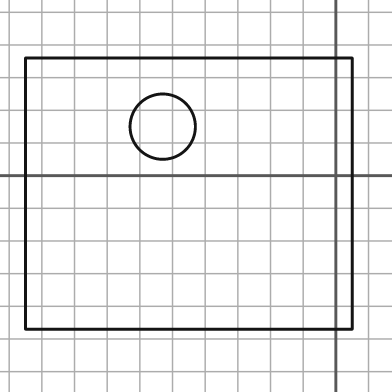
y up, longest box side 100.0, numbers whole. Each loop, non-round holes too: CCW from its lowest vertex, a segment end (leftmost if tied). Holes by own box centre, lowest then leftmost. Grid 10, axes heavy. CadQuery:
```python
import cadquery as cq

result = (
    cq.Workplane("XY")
    .moveTo(-95.0, -47.0)
    .lineTo(5.0, -47.0)
    .lineTo(5.0, 36.0)
    .lineTo(-95.0, 36.0)
    .close()
    .moveTo(-53.0, 15.0)
    .circle(10.0)
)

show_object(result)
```